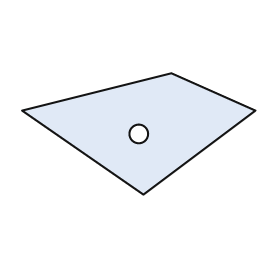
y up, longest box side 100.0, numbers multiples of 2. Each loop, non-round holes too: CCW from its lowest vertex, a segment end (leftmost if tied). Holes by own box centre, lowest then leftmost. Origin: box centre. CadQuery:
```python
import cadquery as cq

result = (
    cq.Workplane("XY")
    .moveTo(2.0, -26.0)
    .lineTo(50.0, 10.0)
    .lineTo(14.0, 26.0)
    .lineTo(-50.0, 10.0)
    .close()
    .moveTo(0.0, 0.0)
    .circle(4.0)
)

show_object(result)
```